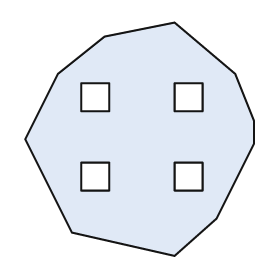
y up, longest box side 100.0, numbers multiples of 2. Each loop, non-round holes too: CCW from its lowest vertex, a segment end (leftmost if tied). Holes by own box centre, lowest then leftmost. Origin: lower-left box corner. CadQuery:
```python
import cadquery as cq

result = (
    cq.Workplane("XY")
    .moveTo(64.0, 0.0)
    .lineTo(82.0, 16.0)
    .lineTo(98.0, 48.0)
    .lineTo(98.0, 58.0)
    .lineTo(90.0, 78.0)
    .lineTo(64.0, 100.0)
    .lineTo(34.0, 94.0)
    .lineTo(14.0, 78.0)
    .lineTo(0.0, 50.0)
    .lineTo(20.0, 10.0)
    .close()
    .moveTo(24.0, 28.0)
    .lineTo(36.0, 28.0)
    .lineTo(36.0, 40.0)
    .lineTo(24.0, 40.0)
    .close()
    .moveTo(64.0, 28.0)
    .lineTo(76.0, 28.0)
    .lineTo(76.0, 40.0)
    .lineTo(64.0, 40.0)
    .close()
    .moveTo(24.0, 62.0)
    .lineTo(36.0, 62.0)
    .lineTo(36.0, 74.0)
    .lineTo(24.0, 74.0)
    .close()
    .moveTo(64.0, 62.0)
    .lineTo(76.0, 62.0)
    .lineTo(76.0, 74.0)
    .lineTo(64.0, 74.0)
    .close()
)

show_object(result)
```